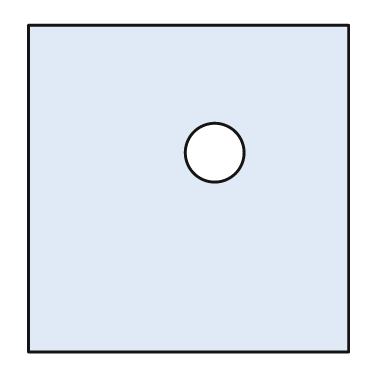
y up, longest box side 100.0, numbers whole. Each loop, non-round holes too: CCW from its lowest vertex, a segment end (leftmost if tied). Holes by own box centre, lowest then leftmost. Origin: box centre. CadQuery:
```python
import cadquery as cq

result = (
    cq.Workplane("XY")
    .moveTo(-49.0, -50.0)
    .lineTo(49.0, -50.0)
    .lineTo(49.0, 50.0)
    .lineTo(-49.0, 50.0)
    .close()
    .moveTo(8.0, 11.0)
    .circle(9.0)
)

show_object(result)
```